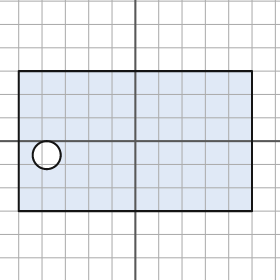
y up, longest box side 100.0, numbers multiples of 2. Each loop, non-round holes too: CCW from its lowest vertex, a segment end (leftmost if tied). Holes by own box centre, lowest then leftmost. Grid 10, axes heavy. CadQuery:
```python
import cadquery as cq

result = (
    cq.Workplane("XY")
    .moveTo(-50.0, -30.0)
    .lineTo(50.0, -30.0)
    .lineTo(50.0, 30.0)
    .lineTo(-50.0, 30.0)
    .close()
    .moveTo(-38.0, -6.0)
    .circle(6.0)
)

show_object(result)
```